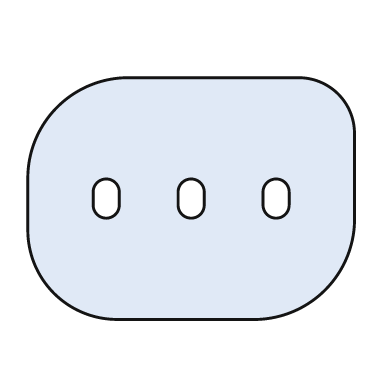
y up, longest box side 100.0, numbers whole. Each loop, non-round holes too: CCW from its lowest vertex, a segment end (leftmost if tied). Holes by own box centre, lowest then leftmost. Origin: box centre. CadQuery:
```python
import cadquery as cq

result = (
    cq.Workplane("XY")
    .moveTo(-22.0, -37.0)
    .lineTo(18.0, -37.0)
    .threePointArc((41.0, -28.0), (50.0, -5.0))
    .lineTo(50.0, 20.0)
    .threePointArc((45.0, 32.0), (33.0, 37.0))
    .lineTo(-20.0, 37.0)
    .threePointArc((-41.0, 28.0), (-50.0, 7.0))
    .lineTo(-50.0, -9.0)
    .threePointArc((-42.0, -29.0), (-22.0, -37.0))
    .close()
    .moveTo(-30.0, -2.0)
    .threePointArc((-26.0, -6.0), (-22.0, -2.0))
    .lineTo(-22.0, 2.0)
    .threePointArc((-26.0, 6.0), (-30.0, 2.0))
    .close()
    .moveTo(-4.0, -2.0)
    .threePointArc((0.0, -6.0), (4.0, -2.0))
    .lineTo(4.0, 2.0)
    .threePointArc((0.0, 6.0), (-4.0, 2.0))
    .close()
    .moveTo(22.0, -2.0)
    .threePointArc((26.0, -6.0), (30.0, -2.0))
    .lineTo(30.0, 2.0)
    .threePointArc((26.0, 6.0), (22.0, 2.0))
    .close()
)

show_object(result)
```